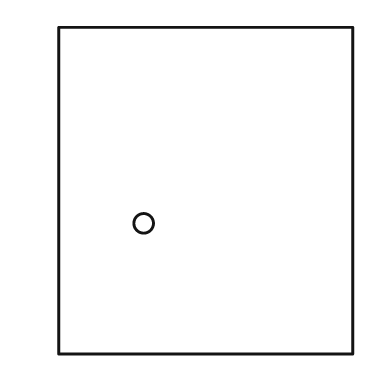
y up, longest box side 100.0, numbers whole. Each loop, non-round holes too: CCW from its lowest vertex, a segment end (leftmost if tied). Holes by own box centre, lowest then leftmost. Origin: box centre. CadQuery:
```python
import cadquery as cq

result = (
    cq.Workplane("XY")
    .moveTo(-45.0, -50.0)
    .lineTo(45.0, -50.0)
    .lineTo(45.0, 50.0)
    .lineTo(-45.0, 50.0)
    .close()
    .moveTo(-19.0, -10.0)
    .circle(3.0)
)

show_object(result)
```